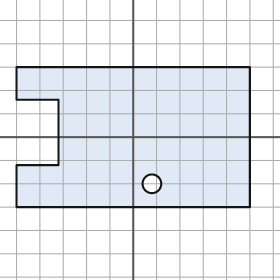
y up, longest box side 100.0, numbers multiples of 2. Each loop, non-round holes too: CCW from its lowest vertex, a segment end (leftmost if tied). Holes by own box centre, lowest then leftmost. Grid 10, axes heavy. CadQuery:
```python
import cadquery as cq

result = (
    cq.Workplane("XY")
    .moveTo(-50.0, -30.0)
    .lineTo(50.0, -30.0)
    .lineTo(50.0, 30.0)
    .lineTo(-50.0, 30.0)
    .lineTo(-50.0, 16.0)
    .lineTo(-32.0, 16.0)
    .lineTo(-32.0, -12.0)
    .lineTo(-50.0, -12.0)
    .close()
    .moveTo(8.0, -20.0)
    .circle(4.0)
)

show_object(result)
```